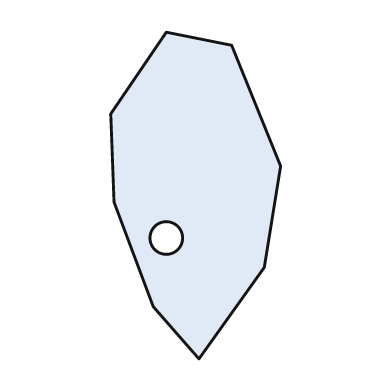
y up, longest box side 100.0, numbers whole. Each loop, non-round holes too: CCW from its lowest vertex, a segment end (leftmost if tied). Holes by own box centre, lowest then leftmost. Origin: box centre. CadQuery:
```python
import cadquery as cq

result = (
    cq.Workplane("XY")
    .moveTo(1.0, -50.0)
    .lineTo(21.0, -22.0)
    .lineTo(26.0, 9.0)
    .lineTo(11.0, 46.0)
    .lineTo(-9.0, 50.0)
    .lineTo(-26.0, 25.0)
    .lineTo(-25.0, -2.0)
    .lineTo(-13.0, -34.0)
    .close()
    .moveTo(-9.0, -13.0)
    .circle(5.0)
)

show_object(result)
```